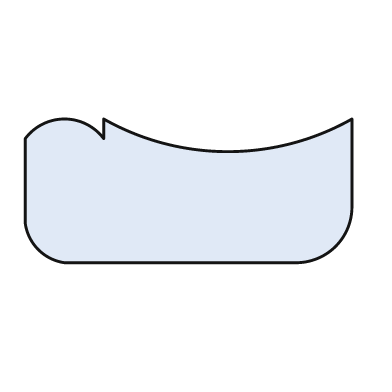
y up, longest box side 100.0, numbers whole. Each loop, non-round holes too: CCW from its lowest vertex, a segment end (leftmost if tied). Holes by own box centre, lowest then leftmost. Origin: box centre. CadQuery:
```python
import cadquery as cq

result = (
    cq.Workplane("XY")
    .moveTo(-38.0, -22.0)
    .lineTo(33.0, -22.0)
    .threePointArc((45.0, -17.0), (50.0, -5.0))
    .lineTo(50.0, 22.0)
    .threePointArc((12.0, 12.0), (-26.0, 22.0))
    .lineTo(-26.0, 16.0)
    .threePointArc((-38.0, 22.0), (-50.0, 16.0))
    .lineTo(-50.0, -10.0)
    .threePointArc((-46.0, -18.0), (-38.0, -22.0))
    .close()
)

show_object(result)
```